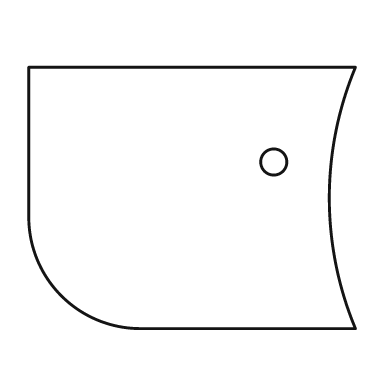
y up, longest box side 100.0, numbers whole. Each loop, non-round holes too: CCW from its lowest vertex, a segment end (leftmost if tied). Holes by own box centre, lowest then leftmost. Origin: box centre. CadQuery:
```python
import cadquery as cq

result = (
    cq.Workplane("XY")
    .moveTo(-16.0, -40.0)
    .lineTo(50.0, -40.0)
    .threePointArc((42.0, 0.0), (50.0, 40.0))
    .lineTo(-50.0, 40.0)
    .lineTo(-50.0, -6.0)
    .threePointArc((-40.0, -30.0), (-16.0, -40.0))
    .close()
    .moveTo(25.0, 11.0)
    .circle(4.0)
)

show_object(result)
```